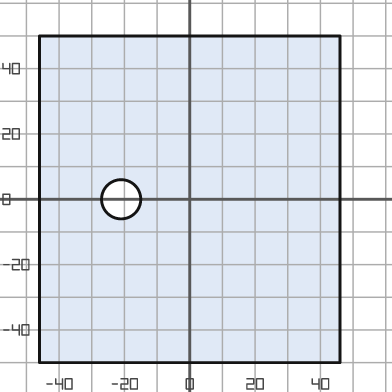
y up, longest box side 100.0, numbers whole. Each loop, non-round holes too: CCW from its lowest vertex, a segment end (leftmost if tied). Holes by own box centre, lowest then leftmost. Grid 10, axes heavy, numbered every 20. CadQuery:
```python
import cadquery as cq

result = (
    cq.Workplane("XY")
    .moveTo(-46.0, -50.0)
    .lineTo(46.0, -50.0)
    .lineTo(46.0, 50.0)
    .lineTo(-46.0, 50.0)
    .close()
    .moveTo(-21.0, 0.0)
    .circle(6.0)
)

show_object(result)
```